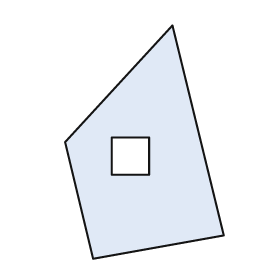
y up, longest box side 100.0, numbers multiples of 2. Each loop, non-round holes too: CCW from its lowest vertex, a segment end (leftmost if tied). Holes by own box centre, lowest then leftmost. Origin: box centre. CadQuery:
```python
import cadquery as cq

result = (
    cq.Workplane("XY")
    .moveTo(-22.0, -50.0)
    .lineTo(34.0, -40.0)
    .lineTo(12.0, 50.0)
    .lineTo(-34.0, 0.0)
    .close()
    .moveTo(-14.0, -14.0)
    .lineTo(2.0, -14.0)
    .lineTo(2.0, 2.0)
    .lineTo(-14.0, 2.0)
    .close()
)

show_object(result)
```